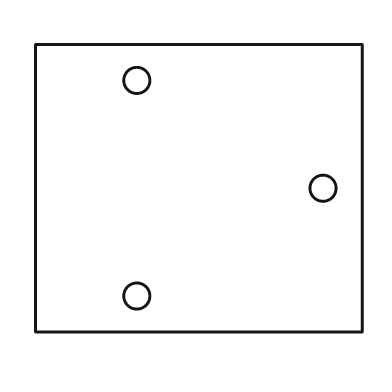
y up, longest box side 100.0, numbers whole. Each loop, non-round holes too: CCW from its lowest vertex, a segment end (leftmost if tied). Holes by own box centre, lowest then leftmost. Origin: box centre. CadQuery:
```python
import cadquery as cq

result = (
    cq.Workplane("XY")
    .moveTo(-50.0, -44.0)
    .lineTo(50.0, -44.0)
    .lineTo(50.0, 44.0)
    .lineTo(-50.0, 44.0)
    .close()
    .moveTo(-19.0, -33.0)
    .circle(4.0)
    .moveTo(38.0, 0.0)
    .circle(4.0)
    .moveTo(-19.0, 33.0)
    .circle(4.0)
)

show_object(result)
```